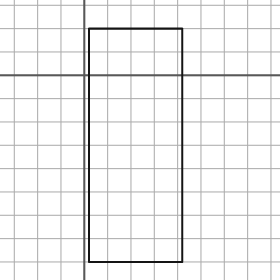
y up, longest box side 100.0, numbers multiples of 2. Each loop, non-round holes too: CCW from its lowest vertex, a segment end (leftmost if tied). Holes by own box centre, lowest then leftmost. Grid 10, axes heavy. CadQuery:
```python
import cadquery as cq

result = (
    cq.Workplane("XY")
    .moveTo(2.0, -80.0)
    .lineTo(42.0, -80.0)
    .lineTo(42.0, 20.0)
    .lineTo(2.0, 20.0)
    .close()
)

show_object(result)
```